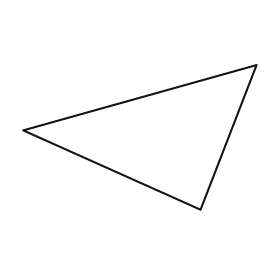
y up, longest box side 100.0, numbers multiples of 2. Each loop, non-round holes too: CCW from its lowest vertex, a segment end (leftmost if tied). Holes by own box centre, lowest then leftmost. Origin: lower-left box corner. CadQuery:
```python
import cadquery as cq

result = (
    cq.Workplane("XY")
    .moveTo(76.0, 0.0)
    .lineTo(100.0, 62.0)
    .lineTo(0.0, 34.0)
    .close()
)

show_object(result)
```